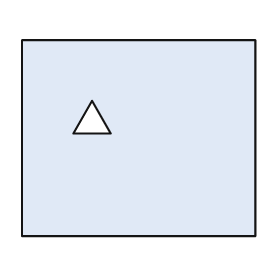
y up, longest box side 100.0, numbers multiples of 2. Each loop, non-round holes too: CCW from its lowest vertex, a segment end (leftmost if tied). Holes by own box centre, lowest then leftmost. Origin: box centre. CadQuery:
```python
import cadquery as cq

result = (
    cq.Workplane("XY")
    .moveTo(-50.0, -42.0)
    .lineTo(50.0, -42.0)
    .lineTo(50.0, 42.0)
    .lineTo(-50.0, 42.0)
    .close()
    .moveTo(-28.0, 2.0)
    .lineTo(-12.0, 2.0)
    .lineTo(-20.0, 16.0)
    .close()
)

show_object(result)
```